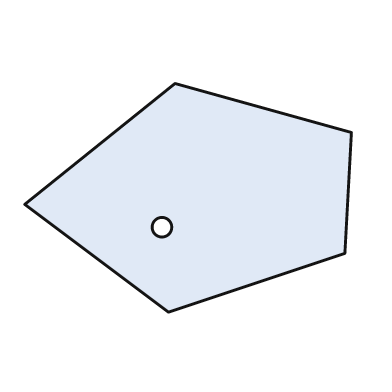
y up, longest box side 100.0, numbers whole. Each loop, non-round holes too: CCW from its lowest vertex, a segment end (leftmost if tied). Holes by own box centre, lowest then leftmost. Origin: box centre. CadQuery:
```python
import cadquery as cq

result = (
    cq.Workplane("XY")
    .moveTo(-6.0, -35.0)
    .lineTo(48.0, -17.0)
    .lineTo(50.0, 20.0)
    .lineTo(-4.0, 35.0)
    .lineTo(-50.0, -2.0)
    .close()
    .moveTo(-8.0, -9.0)
    .circle(3.0)
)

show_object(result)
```